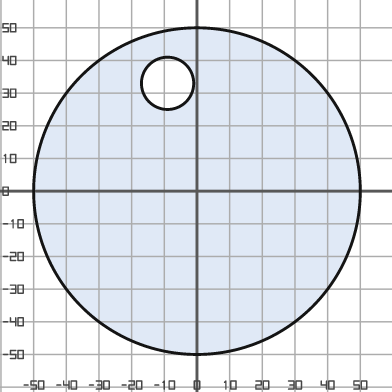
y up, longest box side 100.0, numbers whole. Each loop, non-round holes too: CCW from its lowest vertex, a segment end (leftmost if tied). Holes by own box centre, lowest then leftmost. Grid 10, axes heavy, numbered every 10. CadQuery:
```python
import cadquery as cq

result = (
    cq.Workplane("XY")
    .moveTo(0.0, 0.0)
    .circle(50.0)
    .moveTo(-9.0, 33.0)
    .circle(8.0)
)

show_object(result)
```